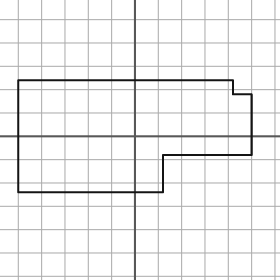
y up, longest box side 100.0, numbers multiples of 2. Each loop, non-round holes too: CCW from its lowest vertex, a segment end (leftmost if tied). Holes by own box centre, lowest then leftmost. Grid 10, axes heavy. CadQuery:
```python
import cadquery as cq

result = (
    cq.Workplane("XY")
    .moveTo(-50.0, -24.0)
    .lineTo(12.0, -24.0)
    .lineTo(12.0, -8.0)
    .lineTo(50.0, -8.0)
    .lineTo(50.0, 18.0)
    .lineTo(42.0, 18.0)
    .lineTo(42.0, 24.0)
    .lineTo(-50.0, 24.0)
    .close()
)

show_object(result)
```